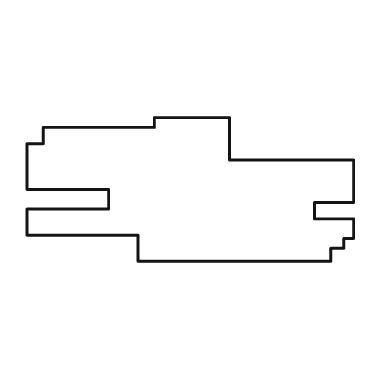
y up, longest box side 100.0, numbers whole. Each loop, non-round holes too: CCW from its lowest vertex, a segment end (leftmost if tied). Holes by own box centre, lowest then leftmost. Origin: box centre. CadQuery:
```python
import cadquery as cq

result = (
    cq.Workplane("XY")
    .moveTo(-16.0, -22.0)
    .lineTo(43.0, -22.0)
    .lineTo(43.0, -18.0)
    .lineTo(47.0, -18.0)
    .lineTo(47.0, -15.0)
    .lineTo(50.0, -15.0)
    .lineTo(50.0, -9.0)
    .lineTo(38.0, -9.0)
    .lineTo(38.0, -4.0)
    .lineTo(50.0, -4.0)
    .lineTo(50.0, 9.0)
    .lineTo(12.0, 9.0)
    .lineTo(12.0, 22.0)
    .lineTo(-11.0, 22.0)
    .lineTo(-11.0, 19.0)
    .lineTo(-45.0, 19.0)
    .lineTo(-45.0, 14.0)
    .lineTo(-50.0, 14.0)
    .lineTo(-50.0, 0.0)
    .lineTo(-25.0, 0.0)
    .lineTo(-25.0, -6.0)
    .lineTo(-50.0, -6.0)
    .lineTo(-50.0, -14.0)
    .lineTo(-16.0, -14.0)
    .close()
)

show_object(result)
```